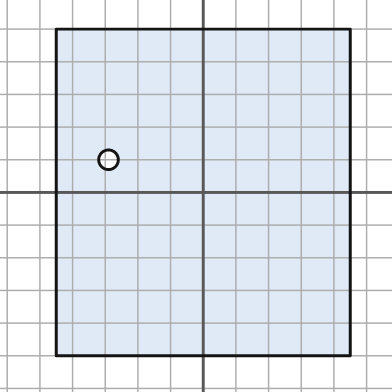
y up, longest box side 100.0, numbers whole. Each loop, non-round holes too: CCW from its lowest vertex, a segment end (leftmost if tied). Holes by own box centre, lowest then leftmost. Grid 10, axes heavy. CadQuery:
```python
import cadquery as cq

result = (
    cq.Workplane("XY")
    .moveTo(-45.0, -50.0)
    .lineTo(45.0, -50.0)
    .lineTo(45.0, 50.0)
    .lineTo(-45.0, 50.0)
    .close()
    .moveTo(-29.0, 10.0)
    .circle(3.0)
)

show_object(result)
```